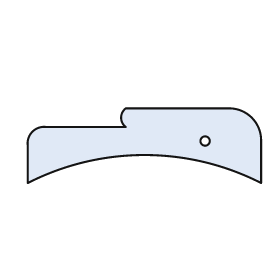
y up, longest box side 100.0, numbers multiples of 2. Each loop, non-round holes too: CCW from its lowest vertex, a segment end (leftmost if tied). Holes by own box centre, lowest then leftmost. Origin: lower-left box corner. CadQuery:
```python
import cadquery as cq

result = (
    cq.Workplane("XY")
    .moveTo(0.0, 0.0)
    .threePointArc((50.0, 12.0), (100.0, 0.0))
    .lineTo(100.0, 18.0)
    .threePointArc((96.0, 28.0), (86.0, 32.0))
    .lineTo(42.0, 32.0)
    .threePointArc((40.0, 28.0), (42.0, 24.0))
    .lineTo(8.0, 24.0)
    .threePointArc((2.0, 22.0), (0.0, 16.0))
    .close()
    .moveTo(76.0, 18.0)
    .circle(2.0)
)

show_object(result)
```